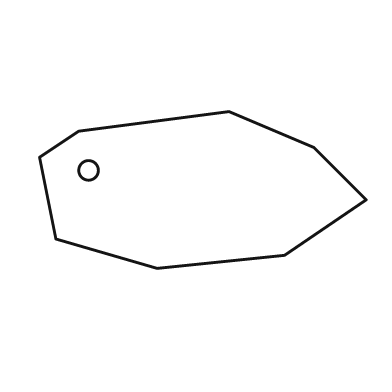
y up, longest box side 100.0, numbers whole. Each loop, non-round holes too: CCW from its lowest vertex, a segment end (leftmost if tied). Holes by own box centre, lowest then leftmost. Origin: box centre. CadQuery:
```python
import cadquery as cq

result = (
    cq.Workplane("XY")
    .moveTo(-14.0, -24.0)
    .lineTo(25.0, -20.0)
    .lineTo(50.0, -3.0)
    .lineTo(34.0, 13.0)
    .lineTo(8.0, 24.0)
    .lineTo(-38.0, 18.0)
    .lineTo(-50.0, 10.0)
    .lineTo(-45.0, -15.0)
    .close()
    .moveTo(-35.0, 6.0)
    .circle(3.0)
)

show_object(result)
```